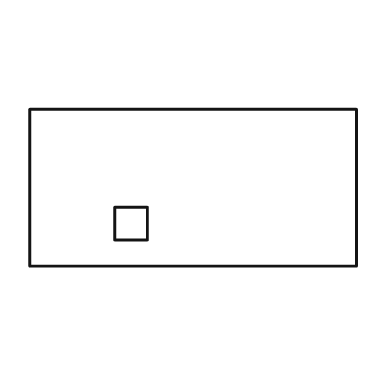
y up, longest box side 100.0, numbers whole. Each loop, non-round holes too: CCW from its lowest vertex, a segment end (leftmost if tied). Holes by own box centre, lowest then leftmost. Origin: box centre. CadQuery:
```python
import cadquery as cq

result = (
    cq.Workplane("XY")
    .moveTo(-50.0, -24.0)
    .lineTo(50.0, -24.0)
    .lineTo(50.0, 24.0)
    .lineTo(-50.0, 24.0)
    .close()
    .moveTo(-24.0, -16.0)
    .lineTo(-14.0, -16.0)
    .lineTo(-14.0, -6.0)
    .lineTo(-24.0, -6.0)
    .close()
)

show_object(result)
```